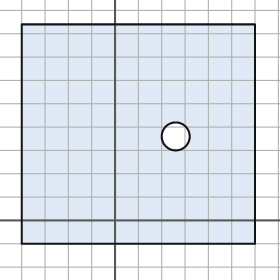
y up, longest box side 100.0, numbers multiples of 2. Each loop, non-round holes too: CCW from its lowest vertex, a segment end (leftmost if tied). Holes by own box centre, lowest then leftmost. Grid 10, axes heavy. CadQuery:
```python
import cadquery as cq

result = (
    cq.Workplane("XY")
    .moveTo(-40.0, -10.0)
    .lineTo(60.0, -10.0)
    .lineTo(60.0, 84.0)
    .lineTo(-40.0, 84.0)
    .close()
    .moveTo(26.0, 36.0)
    .circle(6.0)
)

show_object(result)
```